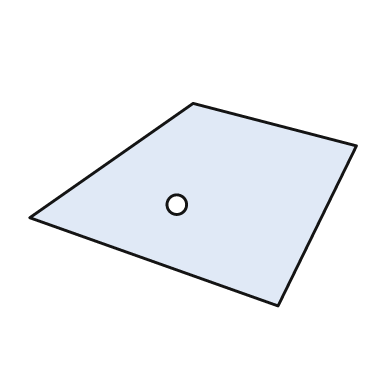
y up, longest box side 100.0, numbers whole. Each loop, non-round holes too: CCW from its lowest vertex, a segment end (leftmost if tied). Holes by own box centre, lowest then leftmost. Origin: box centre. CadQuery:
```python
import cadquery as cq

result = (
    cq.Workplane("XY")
    .moveTo(26.0, -31.0)
    .lineTo(50.0, 18.0)
    .lineTo(0.0, 31.0)
    .lineTo(-50.0, -4.0)
    .close()
    .moveTo(-5.0, 0.0)
    .circle(3.0)
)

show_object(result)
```